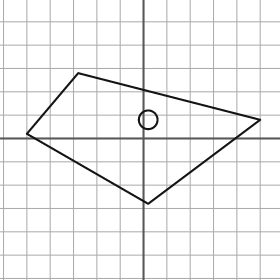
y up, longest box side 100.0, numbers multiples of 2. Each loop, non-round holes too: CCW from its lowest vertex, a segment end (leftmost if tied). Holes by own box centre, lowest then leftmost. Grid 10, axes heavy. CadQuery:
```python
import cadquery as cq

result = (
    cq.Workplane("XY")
    .moveTo(2.0, -28.0)
    .lineTo(50.0, 8.0)
    .lineTo(-28.0, 28.0)
    .lineTo(-50.0, 2.0)
    .close()
    .moveTo(2.0, 8.0)
    .circle(4.0)
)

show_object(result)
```